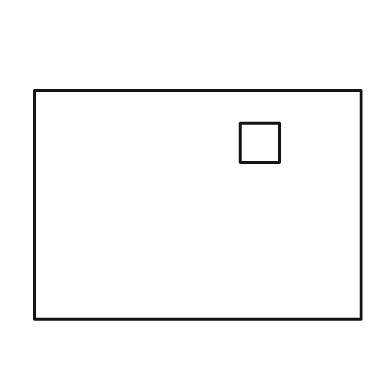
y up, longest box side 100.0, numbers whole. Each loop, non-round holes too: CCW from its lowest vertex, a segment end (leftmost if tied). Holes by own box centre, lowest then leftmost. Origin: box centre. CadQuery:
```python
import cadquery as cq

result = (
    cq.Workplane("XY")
    .moveTo(-50.0, -35.0)
    .lineTo(50.0, -35.0)
    .lineTo(50.0, 35.0)
    .lineTo(-50.0, 35.0)
    .close()
    .moveTo(13.0, 13.0)
    .lineTo(25.0, 13.0)
    .lineTo(25.0, 25.0)
    .lineTo(13.0, 25.0)
    .close()
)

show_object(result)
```